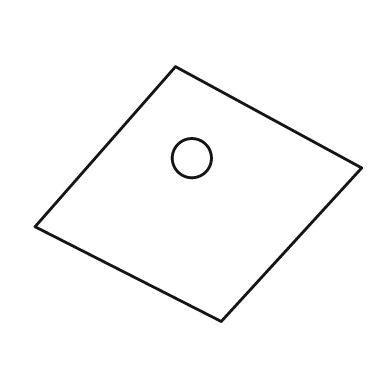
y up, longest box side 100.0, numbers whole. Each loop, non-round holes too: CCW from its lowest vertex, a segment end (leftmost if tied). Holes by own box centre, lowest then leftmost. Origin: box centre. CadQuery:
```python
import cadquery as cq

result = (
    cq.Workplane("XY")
    .moveTo(7.0, -39.0)
    .lineTo(50.0, 8.0)
    .lineTo(-7.0, 39.0)
    .lineTo(-50.0, -10.0)
    .close()
    .moveTo(-2.0, 11.0)
    .circle(6.0)
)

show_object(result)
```